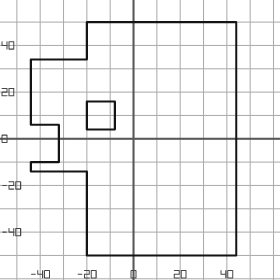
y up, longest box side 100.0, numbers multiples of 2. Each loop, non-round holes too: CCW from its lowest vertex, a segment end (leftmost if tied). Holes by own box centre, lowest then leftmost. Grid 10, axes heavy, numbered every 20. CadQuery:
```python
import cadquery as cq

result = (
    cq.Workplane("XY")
    .moveTo(-20.0, -50.0)
    .lineTo(44.0, -50.0)
    .lineTo(44.0, 50.0)
    .lineTo(-20.0, 50.0)
    .lineTo(-20.0, 34.0)
    .lineTo(-44.0, 34.0)
    .lineTo(-44.0, 6.0)
    .lineTo(-32.0, 6.0)
    .lineTo(-32.0, -10.0)
    .lineTo(-44.0, -10.0)
    .lineTo(-44.0, -14.0)
    .lineTo(-20.0, -14.0)
    .close()
    .moveTo(-20.0, 4.0)
    .lineTo(-8.0, 4.0)
    .lineTo(-8.0, 16.0)
    .lineTo(-20.0, 16.0)
    .close()
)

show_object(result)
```